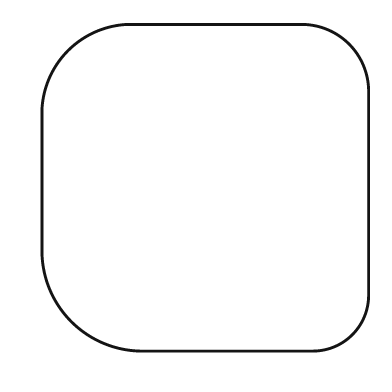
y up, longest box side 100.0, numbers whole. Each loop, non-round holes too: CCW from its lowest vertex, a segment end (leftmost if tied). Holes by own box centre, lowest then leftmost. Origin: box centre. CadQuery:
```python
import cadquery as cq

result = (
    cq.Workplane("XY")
    .moveTo(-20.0, -50.0)
    .lineTo(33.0, -50.0)
    .threePointArc((45.0, -45.0), (50.0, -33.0))
    .lineTo(50.0, 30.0)
    .threePointArc((44.0, 44.0), (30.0, 50.0))
    .lineTo(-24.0, 50.0)
    .threePointArc((-42.0, 42.0), (-50.0, 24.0))
    .lineTo(-50.0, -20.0)
    .threePointArc((-41.0, -41.0), (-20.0, -50.0))
    .close()
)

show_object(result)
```